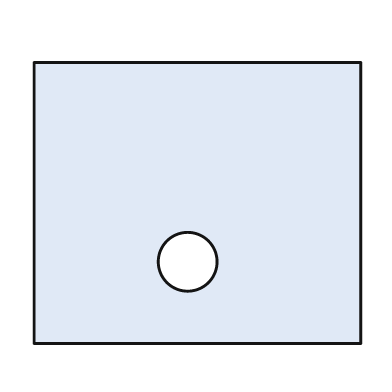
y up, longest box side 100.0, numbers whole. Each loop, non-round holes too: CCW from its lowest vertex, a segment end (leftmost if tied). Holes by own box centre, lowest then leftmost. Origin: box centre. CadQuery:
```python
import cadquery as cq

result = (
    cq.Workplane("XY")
    .moveTo(-50.0, -43.0)
    .lineTo(50.0, -43.0)
    .lineTo(50.0, 43.0)
    .lineTo(-50.0, 43.0)
    .close()
    .moveTo(-3.0, -18.0)
    .circle(9.0)
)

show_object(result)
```